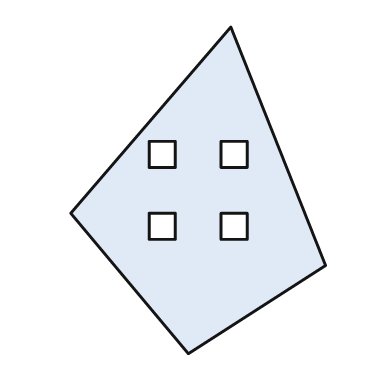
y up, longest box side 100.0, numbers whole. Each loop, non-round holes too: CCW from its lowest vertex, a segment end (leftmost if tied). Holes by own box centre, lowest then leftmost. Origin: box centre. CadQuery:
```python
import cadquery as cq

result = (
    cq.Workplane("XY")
    .moveTo(-3.0, -50.0)
    .lineTo(39.0, -23.0)
    .lineTo(10.0, 50.0)
    .lineTo(-39.0, -7.0)
    .close()
    .moveTo(-15.0, -15.0)
    .lineTo(-7.0, -15.0)
    .lineTo(-7.0, -7.0)
    .lineTo(-15.0, -7.0)
    .close()
    .moveTo(7.0, -15.0)
    .lineTo(15.0, -15.0)
    .lineTo(15.0, -7.0)
    .lineTo(7.0, -7.0)
    .close()
    .moveTo(-15.0, 7.0)
    .lineTo(-7.0, 7.0)
    .lineTo(-7.0, 15.0)
    .lineTo(-15.0, 15.0)
    .close()
    .moveTo(7.0, 7.0)
    .lineTo(15.0, 7.0)
    .lineTo(15.0, 15.0)
    .lineTo(7.0, 15.0)
    .close()
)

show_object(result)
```